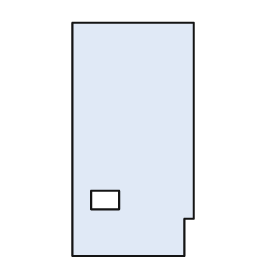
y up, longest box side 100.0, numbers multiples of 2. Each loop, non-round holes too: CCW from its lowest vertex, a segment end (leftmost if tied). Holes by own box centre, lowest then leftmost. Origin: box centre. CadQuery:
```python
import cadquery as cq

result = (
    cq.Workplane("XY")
    .moveTo(-26.0, -50.0)
    .lineTo(22.0, -50.0)
    .lineTo(22.0, -34.0)
    .lineTo(26.0, -34.0)
    .lineTo(26.0, 50.0)
    .lineTo(-26.0, 50.0)
    .close()
    .moveTo(-18.0, -30.0)
    .lineTo(-6.0, -30.0)
    .lineTo(-6.0, -22.0)
    .lineTo(-18.0, -22.0)
    .close()
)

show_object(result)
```